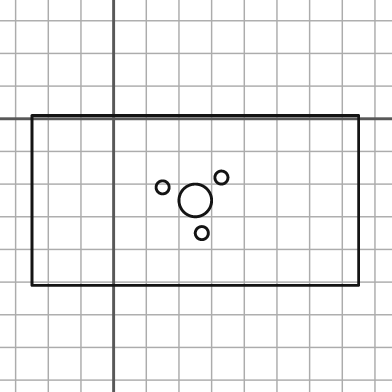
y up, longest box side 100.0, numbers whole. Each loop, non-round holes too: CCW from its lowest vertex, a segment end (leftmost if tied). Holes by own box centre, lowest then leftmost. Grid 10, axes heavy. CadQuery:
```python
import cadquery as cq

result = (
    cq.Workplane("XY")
    .moveTo(-25.0, -51.0)
    .lineTo(75.0, -51.0)
    .lineTo(75.0, 1.0)
    .lineTo(-25.0, 1.0)
    .close()
    .moveTo(27.0, -35.0)
    .circle(2.0)
    .moveTo(25.0, -25.0)
    .circle(5.0)
    .moveTo(15.0, -21.0)
    .circle(2.0)
    .moveTo(33.0, -18.0)
    .circle(2.0)
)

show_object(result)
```